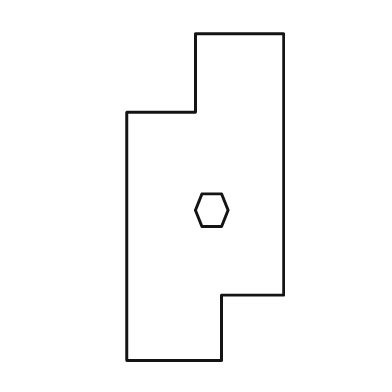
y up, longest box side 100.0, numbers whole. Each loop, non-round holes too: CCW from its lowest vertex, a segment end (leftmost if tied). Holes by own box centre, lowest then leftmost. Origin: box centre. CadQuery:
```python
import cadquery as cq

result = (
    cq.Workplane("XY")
    .moveTo(-24.0, -50.0)
    .lineTo(5.0, -50.0)
    .lineTo(5.0, -30.0)
    .lineTo(24.0, -30.0)
    .lineTo(24.0, 50.0)
    .lineTo(-3.0, 50.0)
    .lineTo(-3.0, 26.0)
    .lineTo(-24.0, 26.0)
    .close()
    .moveTo(-1.0, -9.0)
    .lineTo(5.0, -9.0)
    .lineTo(7.0, -4.0)
    .lineTo(5.0, 1.0)
    .lineTo(-1.0, 1.0)
    .lineTo(-3.0, -4.0)
    .close()
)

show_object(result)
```